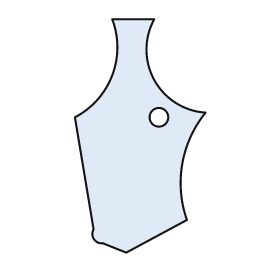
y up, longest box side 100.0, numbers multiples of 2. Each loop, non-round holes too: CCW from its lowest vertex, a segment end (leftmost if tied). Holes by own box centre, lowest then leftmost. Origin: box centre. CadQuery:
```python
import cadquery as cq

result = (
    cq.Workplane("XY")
    .moveTo(-6.0, -50.0)
    .lineTo(20.0, -36.0)
    .threePointArc((18.0, -12.0), (28.0, 10.0))
    .threePointArc((6.0, 24.0), (6.0, 50.0))
    .lineTo(-12.0, 50.0)
    .threePointArc((-12.0, 26.0), (-28.0, 8.0))
    .lineTo(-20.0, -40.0)
    .threePointArc((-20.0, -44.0), (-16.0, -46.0))
    .close()
    .moveTo(8.0, 8.0)
    .circle(4.0)
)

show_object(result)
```